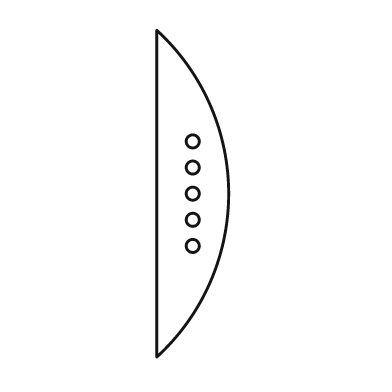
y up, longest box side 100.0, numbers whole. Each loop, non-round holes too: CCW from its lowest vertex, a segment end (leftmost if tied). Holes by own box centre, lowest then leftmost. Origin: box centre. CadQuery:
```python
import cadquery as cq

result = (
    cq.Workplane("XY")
    .moveTo(-11.0, -50.0)
    .threePointArc((11.0, 0.0), (-11.0, 50.0))
    .close()
    .moveTo(0.0, -16.0)
    .circle(2.0)
    .moveTo(0.0, -8.0)
    .circle(2.0)
    .moveTo(0.0, 0.0)
    .circle(2.0)
    .moveTo(0.0, 8.0)
    .circle(2.0)
    .moveTo(0.0, 16.0)
    .circle(2.0)
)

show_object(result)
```